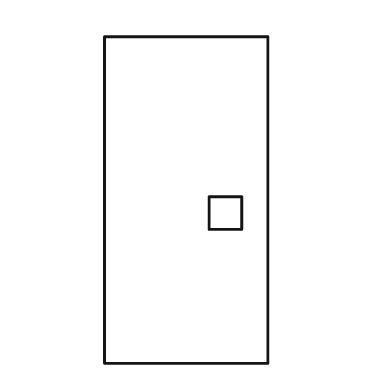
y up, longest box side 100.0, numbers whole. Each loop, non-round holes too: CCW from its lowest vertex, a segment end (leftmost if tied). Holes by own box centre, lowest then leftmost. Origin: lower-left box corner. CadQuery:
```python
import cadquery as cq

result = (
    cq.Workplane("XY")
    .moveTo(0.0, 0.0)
    .lineTo(50.0, 0.0)
    .lineTo(50.0, 100.0)
    .lineTo(0.0, 100.0)
    .close()
    .moveTo(32.0, 41.0)
    .lineTo(42.0, 41.0)
    .lineTo(42.0, 51.0)
    .lineTo(32.0, 51.0)
    .close()
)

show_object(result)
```